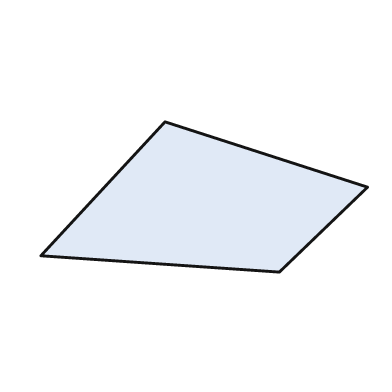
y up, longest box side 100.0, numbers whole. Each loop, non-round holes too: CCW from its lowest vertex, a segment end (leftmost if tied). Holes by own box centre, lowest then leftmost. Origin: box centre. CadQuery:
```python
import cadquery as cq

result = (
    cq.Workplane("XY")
    .moveTo(23.0, -23.0)
    .lineTo(50.0, 3.0)
    .lineTo(-12.0, 23.0)
    .lineTo(-50.0, -18.0)
    .close()
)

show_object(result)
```